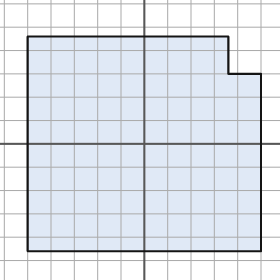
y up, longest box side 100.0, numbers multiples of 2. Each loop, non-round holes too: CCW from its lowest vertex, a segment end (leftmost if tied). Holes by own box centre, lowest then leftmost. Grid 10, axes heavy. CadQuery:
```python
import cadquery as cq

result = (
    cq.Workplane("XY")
    .moveTo(-50.0, -46.0)
    .lineTo(50.0, -46.0)
    .lineTo(50.0, 30.0)
    .lineTo(36.0, 30.0)
    .lineTo(36.0, 46.0)
    .lineTo(-50.0, 46.0)
    .close()
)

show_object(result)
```